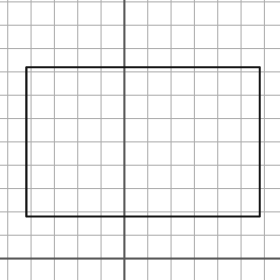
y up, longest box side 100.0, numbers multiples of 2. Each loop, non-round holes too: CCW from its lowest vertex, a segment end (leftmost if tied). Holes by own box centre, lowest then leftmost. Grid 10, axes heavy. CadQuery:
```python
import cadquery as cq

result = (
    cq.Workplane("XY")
    .moveTo(-42.0, 18.0)
    .lineTo(58.0, 18.0)
    .lineTo(58.0, 82.0)
    .lineTo(-42.0, 82.0)
    .close()
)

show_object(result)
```